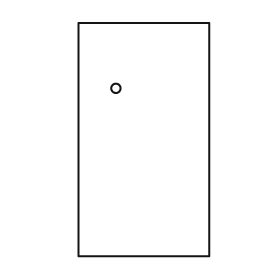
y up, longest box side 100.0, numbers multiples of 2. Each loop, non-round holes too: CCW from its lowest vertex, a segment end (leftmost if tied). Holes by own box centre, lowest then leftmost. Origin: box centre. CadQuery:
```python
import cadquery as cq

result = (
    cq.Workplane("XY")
    .moveTo(-28.0, -50.0)
    .lineTo(28.0, -50.0)
    .lineTo(28.0, 50.0)
    .lineTo(-28.0, 50.0)
    .close()
    .moveTo(-12.0, 22.0)
    .circle(2.0)
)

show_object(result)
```